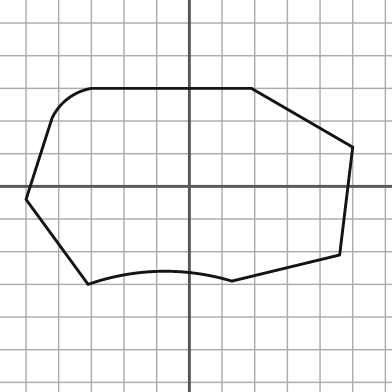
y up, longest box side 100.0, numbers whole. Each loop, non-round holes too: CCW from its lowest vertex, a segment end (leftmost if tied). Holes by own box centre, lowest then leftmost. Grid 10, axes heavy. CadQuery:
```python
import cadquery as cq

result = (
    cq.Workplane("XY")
    .moveTo(-31.0, -30.0)
    .threePointArc((-9.0, -26.0), (13.0, -29.0))
    .lineTo(46.0, -21.0)
    .lineTo(50.0, 12.0)
    .lineTo(19.0, 30.0)
    .lineTo(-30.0, 30.0)
    .threePointArc((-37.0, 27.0), (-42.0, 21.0))
    .lineTo(-50.0, -4.0)
    .close()
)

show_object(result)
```